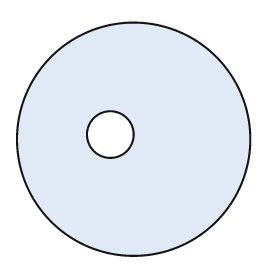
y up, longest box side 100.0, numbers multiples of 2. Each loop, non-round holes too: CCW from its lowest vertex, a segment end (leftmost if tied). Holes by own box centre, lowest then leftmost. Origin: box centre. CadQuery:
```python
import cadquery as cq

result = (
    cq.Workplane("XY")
    .moveTo(0.0, 0.0)
    .circle(50.0)
    .moveTo(-10.0, 2.0)
    .circle(10.0)
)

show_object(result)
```